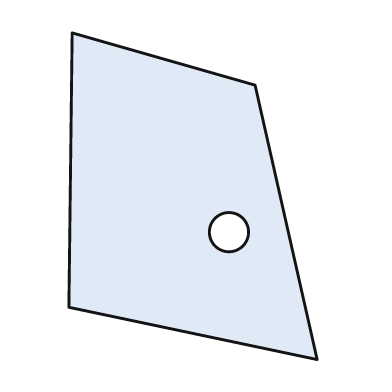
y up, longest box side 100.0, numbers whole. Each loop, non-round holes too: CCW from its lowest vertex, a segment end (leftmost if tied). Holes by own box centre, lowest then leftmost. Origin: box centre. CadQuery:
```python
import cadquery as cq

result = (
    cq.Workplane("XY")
    .moveTo(38.0, -50.0)
    .lineTo(19.0, 34.0)
    .lineTo(-37.0, 50.0)
    .lineTo(-38.0, -34.0)
    .close()
    .moveTo(11.0, -11.0)
    .circle(6.0)
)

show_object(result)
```